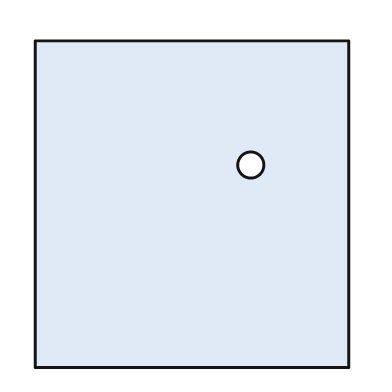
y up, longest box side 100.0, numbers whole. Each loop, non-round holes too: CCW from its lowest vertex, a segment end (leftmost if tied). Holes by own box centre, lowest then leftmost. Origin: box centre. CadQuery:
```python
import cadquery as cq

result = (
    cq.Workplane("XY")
    .moveTo(-48.0, -50.0)
    .lineTo(48.0, -50.0)
    .lineTo(48.0, 50.0)
    .lineTo(-48.0, 50.0)
    .close()
    .moveTo(18.0, 12.0)
    .circle(4.0)
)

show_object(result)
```